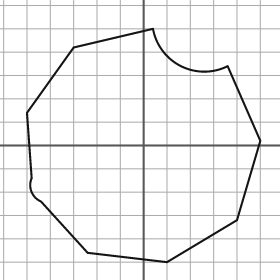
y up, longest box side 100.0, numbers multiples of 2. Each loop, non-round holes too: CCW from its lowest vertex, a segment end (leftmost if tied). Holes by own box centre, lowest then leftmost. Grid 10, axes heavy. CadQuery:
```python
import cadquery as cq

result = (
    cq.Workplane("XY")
    .moveTo(10.0, -50.0)
    .lineTo(40.0, -32.0)
    .lineTo(50.0, 2.0)
    .lineTo(36.0, 34.0)
    .threePointArc((16.0, 34.0), (4.0, 50.0))
    .lineTo(-30.0, 42.0)
    .lineTo(-50.0, 14.0)
    .lineTo(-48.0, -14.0)
    .threePointArc((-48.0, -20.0), (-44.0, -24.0))
    .lineTo(-24.0, -46.0)
    .close()
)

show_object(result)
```